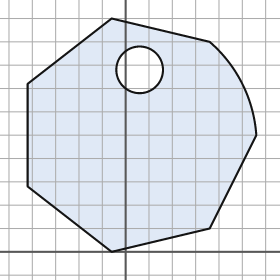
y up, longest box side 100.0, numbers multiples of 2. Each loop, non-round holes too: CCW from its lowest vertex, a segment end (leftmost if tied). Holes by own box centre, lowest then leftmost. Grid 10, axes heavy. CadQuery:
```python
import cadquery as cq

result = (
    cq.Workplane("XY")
    .moveTo(-6.0, 0.0)
    .lineTo(36.0, 10.0)
    .lineTo(56.0, 50.0)
    .threePointArc((50.0, 72.0), (36.0, 90.0))
    .lineTo(-6.0, 100.0)
    .lineTo(-42.0, 72.0)
    .lineTo(-42.0, 28.0)
    .close()
    .moveTo(6.0, 78.0)
    .circle(10.0)
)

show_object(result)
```